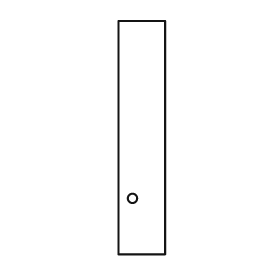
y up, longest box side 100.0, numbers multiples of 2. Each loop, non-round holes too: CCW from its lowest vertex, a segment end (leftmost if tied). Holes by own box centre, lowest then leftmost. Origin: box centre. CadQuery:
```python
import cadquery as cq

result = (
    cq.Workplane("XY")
    .moveTo(-10.0, -50.0)
    .lineTo(10.0, -50.0)
    .lineTo(10.0, 50.0)
    .lineTo(-10.0, 50.0)
    .close()
    .moveTo(-4.0, -26.0)
    .circle(2.0)
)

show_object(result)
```